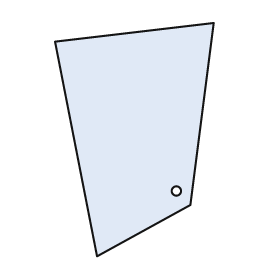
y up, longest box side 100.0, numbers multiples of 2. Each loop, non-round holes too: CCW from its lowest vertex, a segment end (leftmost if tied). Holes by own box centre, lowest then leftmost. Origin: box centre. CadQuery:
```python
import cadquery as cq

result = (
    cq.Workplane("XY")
    .moveTo(-16.0, -50.0)
    .lineTo(24.0, -28.0)
    .lineTo(34.0, 50.0)
    .lineTo(-34.0, 42.0)
    .close()
    .moveTo(18.0, -22.0)
    .circle(2.0)
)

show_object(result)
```